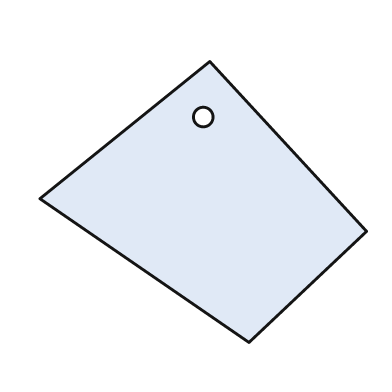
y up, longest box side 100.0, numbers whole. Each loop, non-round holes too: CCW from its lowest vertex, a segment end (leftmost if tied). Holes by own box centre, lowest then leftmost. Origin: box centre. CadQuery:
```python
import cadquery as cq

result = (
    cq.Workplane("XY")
    .moveTo(14.0, -43.0)
    .lineTo(50.0, -9.0)
    .lineTo(2.0, 43.0)
    .lineTo(-50.0, 1.0)
    .close()
    .moveTo(0.0, 26.0)
    .circle(3.0)
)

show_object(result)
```